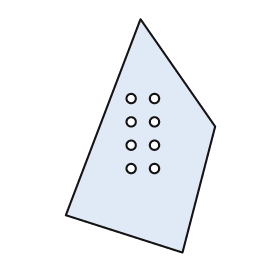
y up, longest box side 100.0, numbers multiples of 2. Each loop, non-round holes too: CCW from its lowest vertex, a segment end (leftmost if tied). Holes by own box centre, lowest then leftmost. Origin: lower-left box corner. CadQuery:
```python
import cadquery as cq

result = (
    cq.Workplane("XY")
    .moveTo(50.0, 0.0)
    .lineTo(64.0, 54.0)
    .lineTo(32.0, 100.0)
    .lineTo(0.0, 16.0)
    .close()
    .moveTo(28.0, 36.0)
    .circle(2.0)
    .moveTo(38.0, 36.0)
    .circle(2.0)
    .moveTo(28.0, 46.0)
    .circle(2.0)
    .moveTo(38.0, 46.0)
    .circle(2.0)
    .moveTo(28.0, 56.0)
    .circle(2.0)
    .moveTo(38.0, 56.0)
    .circle(2.0)
    .moveTo(28.0, 66.0)
    .circle(2.0)
    .moveTo(38.0, 66.0)
    .circle(2.0)
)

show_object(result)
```